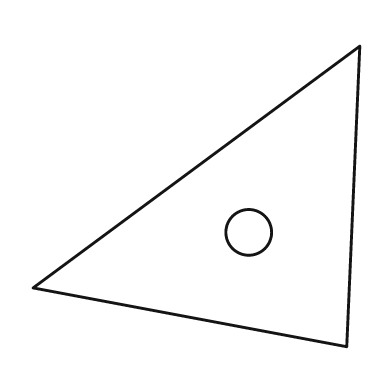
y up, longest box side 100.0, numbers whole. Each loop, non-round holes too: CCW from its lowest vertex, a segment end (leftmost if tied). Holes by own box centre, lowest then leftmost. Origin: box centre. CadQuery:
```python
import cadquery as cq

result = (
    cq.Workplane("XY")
    .moveTo(46.0, -46.0)
    .lineTo(50.0, 46.0)
    .lineTo(-50.0, -28.0)
    .close()
    .moveTo(16.0, -11.0)
    .circle(7.0)
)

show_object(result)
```